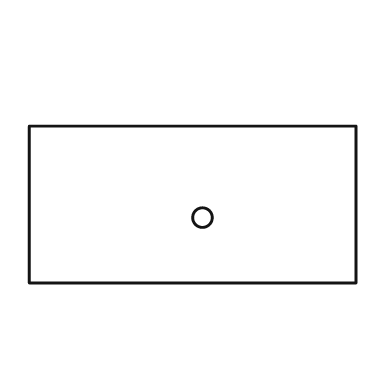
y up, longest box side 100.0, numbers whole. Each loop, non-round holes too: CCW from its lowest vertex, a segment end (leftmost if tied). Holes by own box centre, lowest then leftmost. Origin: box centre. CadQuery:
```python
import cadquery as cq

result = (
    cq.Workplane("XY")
    .moveTo(-50.0, -24.0)
    .lineTo(50.0, -24.0)
    .lineTo(50.0, 24.0)
    .lineTo(-50.0, 24.0)
    .close()
    .moveTo(3.0, -4.0)
    .circle(3.0)
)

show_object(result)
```